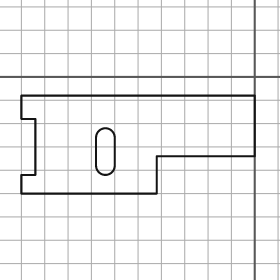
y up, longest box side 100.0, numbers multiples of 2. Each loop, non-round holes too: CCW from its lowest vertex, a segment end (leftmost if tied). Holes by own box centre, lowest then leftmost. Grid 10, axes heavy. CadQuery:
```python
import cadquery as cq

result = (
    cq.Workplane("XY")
    .moveTo(-100.0, -50.0)
    .lineTo(-42.0, -50.0)
    .lineTo(-42.0, -34.0)
    .lineTo(0.0, -34.0)
    .lineTo(0.0, -8.0)
    .lineTo(-100.0, -8.0)
    .lineTo(-100.0, -18.0)
    .lineTo(-94.0, -18.0)
    .lineTo(-94.0, -42.0)
    .lineTo(-100.0, -42.0)
    .close()
    .moveTo(-68.0, -38.0)
    .threePointArc((-64.0, -42.0), (-60.0, -38.0))
    .lineTo(-60.0, -26.0)
    .threePointArc((-64.0, -22.0), (-68.0, -26.0))
    .close()
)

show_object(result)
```